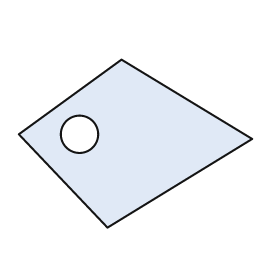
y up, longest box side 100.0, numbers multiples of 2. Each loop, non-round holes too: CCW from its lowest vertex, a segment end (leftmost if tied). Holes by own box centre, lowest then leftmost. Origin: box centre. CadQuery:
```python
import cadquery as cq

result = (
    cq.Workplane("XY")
    .moveTo(-12.0, -36.0)
    .lineTo(50.0, 2.0)
    .lineTo(-6.0, 36.0)
    .lineTo(-50.0, 4.0)
    .close()
    .moveTo(-24.0, 4.0)
    .circle(8.0)
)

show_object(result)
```